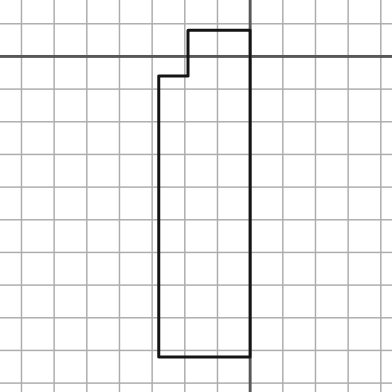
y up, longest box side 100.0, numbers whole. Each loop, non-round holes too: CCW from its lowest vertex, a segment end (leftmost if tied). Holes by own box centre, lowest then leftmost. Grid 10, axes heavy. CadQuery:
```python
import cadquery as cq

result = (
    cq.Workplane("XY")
    .moveTo(-28.0, -92.0)
    .lineTo(0.0, -92.0)
    .lineTo(0.0, 8.0)
    .lineTo(-19.0, 8.0)
    .lineTo(-19.0, -6.0)
    .lineTo(-28.0, -6.0)
    .close()
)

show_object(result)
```